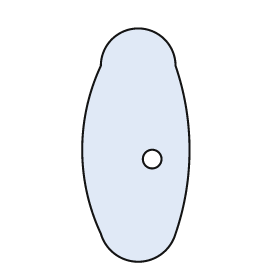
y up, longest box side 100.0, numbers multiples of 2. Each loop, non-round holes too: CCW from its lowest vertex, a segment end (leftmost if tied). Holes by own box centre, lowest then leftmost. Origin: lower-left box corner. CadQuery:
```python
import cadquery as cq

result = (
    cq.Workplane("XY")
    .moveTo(8.0, 12.0)
    .threePointArc((24.0, 0.0), (40.0, 12.0))
    .threePointArc((46.0, 48.0), (40.0, 84.0))
    .threePointArc((24.0, 100.0), (8.0, 84.0))
    .threePointArc((0.0, 48.0), (8.0, 12.0))
    .close()
    .moveTo(30.0, 44.0)
    .circle(4.0)
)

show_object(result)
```